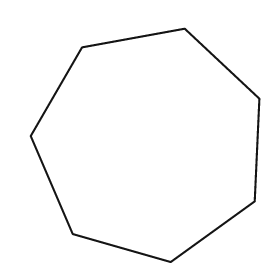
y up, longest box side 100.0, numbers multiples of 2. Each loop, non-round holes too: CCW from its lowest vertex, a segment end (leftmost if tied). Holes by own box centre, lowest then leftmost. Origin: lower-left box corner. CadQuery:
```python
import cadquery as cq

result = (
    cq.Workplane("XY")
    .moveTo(60.0, 0.0)
    .lineTo(96.0, 26.0)
    .lineTo(98.0, 70.0)
    .lineTo(66.0, 100.0)
    .lineTo(22.0, 92.0)
    .lineTo(0.0, 54.0)
    .lineTo(18.0, 12.0)
    .close()
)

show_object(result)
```